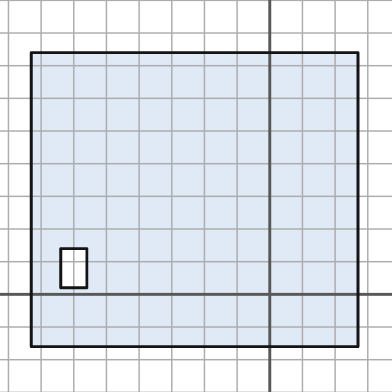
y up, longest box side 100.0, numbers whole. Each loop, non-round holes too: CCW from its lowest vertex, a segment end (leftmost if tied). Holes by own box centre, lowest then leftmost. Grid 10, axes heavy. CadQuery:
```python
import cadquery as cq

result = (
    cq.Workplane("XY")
    .moveTo(-73.0, -16.0)
    .lineTo(27.0, -16.0)
    .lineTo(27.0, 74.0)
    .lineTo(-73.0, 74.0)
    .close()
    .moveTo(-64.0, 2.0)
    .lineTo(-56.0, 2.0)
    .lineTo(-56.0, 14.0)
    .lineTo(-64.0, 14.0)
    .close()
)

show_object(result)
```